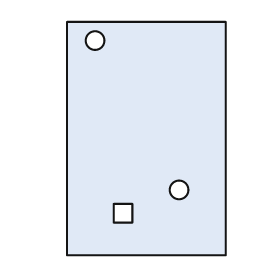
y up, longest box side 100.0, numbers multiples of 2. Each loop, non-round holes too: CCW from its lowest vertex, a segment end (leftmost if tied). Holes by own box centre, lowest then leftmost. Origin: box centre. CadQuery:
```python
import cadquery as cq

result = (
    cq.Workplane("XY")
    .moveTo(-34.0, -50.0)
    .lineTo(34.0, -50.0)
    .lineTo(34.0, 50.0)
    .lineTo(-34.0, 50.0)
    .close()
    .moveTo(-14.0, -36.0)
    .lineTo(-6.0, -36.0)
    .lineTo(-6.0, -28.0)
    .lineTo(-14.0, -28.0)
    .close()
    .moveTo(14.0, -22.0)
    .circle(4.0)
    .moveTo(-22.0, 42.0)
    .circle(4.0)
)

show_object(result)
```